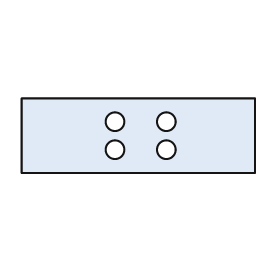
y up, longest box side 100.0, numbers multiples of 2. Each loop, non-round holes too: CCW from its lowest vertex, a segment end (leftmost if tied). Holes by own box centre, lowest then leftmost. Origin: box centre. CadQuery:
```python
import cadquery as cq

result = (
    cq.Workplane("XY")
    .moveTo(-50.0, -16.0)
    .lineTo(50.0, -16.0)
    .lineTo(50.0, 16.0)
    .lineTo(-50.0, 16.0)
    .close()
    .moveTo(-10.0, -6.0)
    .circle(4.0)
    .moveTo(12.0, -6.0)
    .circle(4.0)
    .moveTo(-10.0, 6.0)
    .circle(4.0)
    .moveTo(12.0, 6.0)
    .circle(4.0)
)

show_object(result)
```